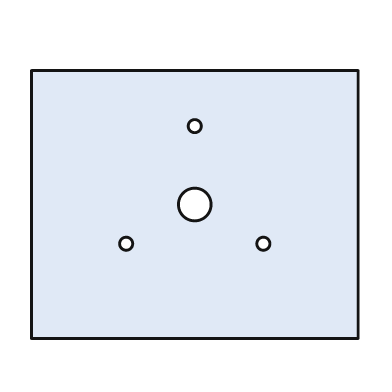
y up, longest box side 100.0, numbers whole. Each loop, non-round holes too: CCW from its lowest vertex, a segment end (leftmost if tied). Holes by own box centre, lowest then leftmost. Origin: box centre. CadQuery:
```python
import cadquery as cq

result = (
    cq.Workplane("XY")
    .moveTo(-50.0, -41.0)
    .lineTo(50.0, -41.0)
    .lineTo(50.0, 41.0)
    .lineTo(-50.0, 41.0)
    .close()
    .moveTo(-21.0, -12.0)
    .circle(2.0)
    .moveTo(21.0, -12.0)
    .circle(2.0)
    .moveTo(0.0, 0.0)
    .circle(5.0)
    .moveTo(0.0, 24.0)
    .circle(2.0)
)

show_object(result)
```